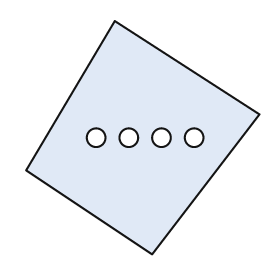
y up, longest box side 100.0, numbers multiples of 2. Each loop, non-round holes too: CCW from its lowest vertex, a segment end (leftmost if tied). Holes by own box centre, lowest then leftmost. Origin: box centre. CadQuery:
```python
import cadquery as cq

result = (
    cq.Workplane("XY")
    .moveTo(4.0, -50.0)
    .lineTo(50.0, 10.0)
    .lineTo(-12.0, 50.0)
    .lineTo(-50.0, -14.0)
    .close()
    .moveTo(-20.0, 0.0)
    .circle(4.0)
    .moveTo(-6.0, 0.0)
    .circle(4.0)
    .moveTo(8.0, 0.0)
    .circle(4.0)
    .moveTo(22.0, 0.0)
    .circle(4.0)
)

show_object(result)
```